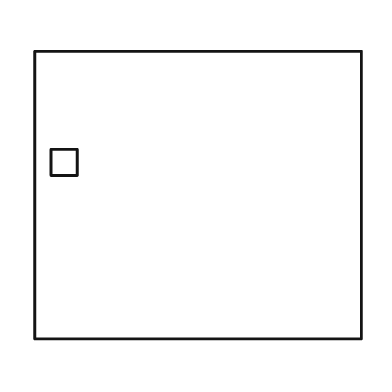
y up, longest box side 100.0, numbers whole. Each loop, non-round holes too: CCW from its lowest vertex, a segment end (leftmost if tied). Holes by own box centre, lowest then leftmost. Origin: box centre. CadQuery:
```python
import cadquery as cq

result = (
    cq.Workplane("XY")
    .moveTo(-50.0, -44.0)
    .lineTo(50.0, -44.0)
    .lineTo(50.0, 44.0)
    .lineTo(-50.0, 44.0)
    .close()
    .moveTo(-45.0, 6.0)
    .lineTo(-37.0, 6.0)
    .lineTo(-37.0, 14.0)
    .lineTo(-45.0, 14.0)
    .close()
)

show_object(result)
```